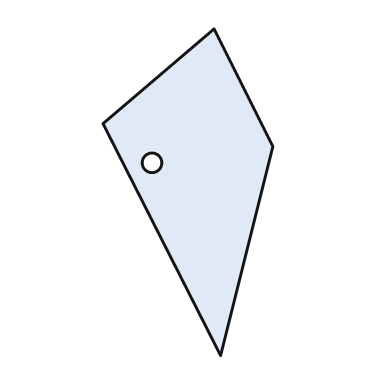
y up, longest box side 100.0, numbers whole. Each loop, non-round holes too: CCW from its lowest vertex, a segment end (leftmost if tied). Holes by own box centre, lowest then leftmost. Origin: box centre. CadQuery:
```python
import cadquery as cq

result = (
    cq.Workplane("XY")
    .moveTo(10.0, -50.0)
    .lineTo(26.0, 14.0)
    .lineTo(8.0, 50.0)
    .lineTo(-26.0, 21.0)
    .close()
    .moveTo(-11.0, 9.0)
    .circle(3.0)
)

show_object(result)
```